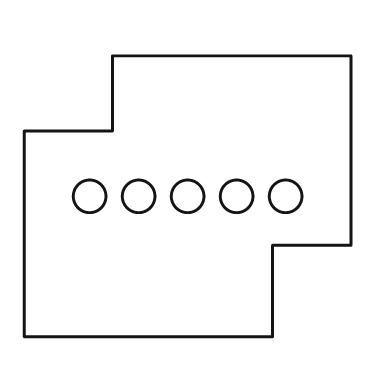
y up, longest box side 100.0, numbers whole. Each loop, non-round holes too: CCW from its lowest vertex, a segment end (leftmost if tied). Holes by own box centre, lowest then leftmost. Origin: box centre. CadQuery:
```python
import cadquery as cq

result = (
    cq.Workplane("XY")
    .moveTo(-50.0, -43.0)
    .lineTo(26.0, -43.0)
    .lineTo(26.0, -15.0)
    .lineTo(50.0, -15.0)
    .lineTo(50.0, 43.0)
    .lineTo(-23.0, 43.0)
    .lineTo(-23.0, 20.0)
    .lineTo(-50.0, 20.0)
    .close()
    .moveTo(-30.0, 0.0)
    .circle(5.0)
    .moveTo(-15.0, 0.0)
    .circle(5.0)
    .moveTo(0.0, 0.0)
    .circle(5.0)
    .moveTo(15.0, 0.0)
    .circle(5.0)
    .moveTo(30.0, 0.0)
    .circle(5.0)
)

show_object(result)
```